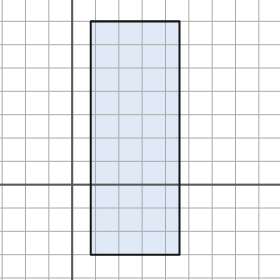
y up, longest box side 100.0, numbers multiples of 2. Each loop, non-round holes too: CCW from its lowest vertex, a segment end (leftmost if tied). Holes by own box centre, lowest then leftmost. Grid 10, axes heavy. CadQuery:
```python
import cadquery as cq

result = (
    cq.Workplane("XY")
    .moveTo(8.0, -30.0)
    .lineTo(46.0, -30.0)
    .lineTo(46.0, 70.0)
    .lineTo(8.0, 70.0)
    .close()
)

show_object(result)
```